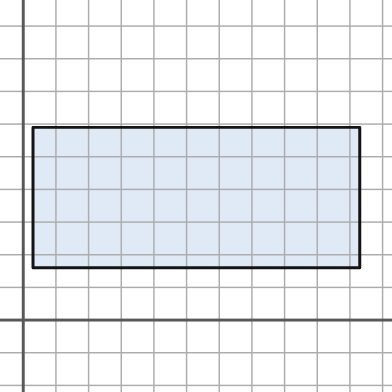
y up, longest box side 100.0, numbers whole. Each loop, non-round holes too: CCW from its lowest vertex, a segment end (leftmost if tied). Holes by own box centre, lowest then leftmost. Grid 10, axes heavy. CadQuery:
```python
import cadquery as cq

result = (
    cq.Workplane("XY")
    .moveTo(3.0, 16.0)
    .lineTo(103.0, 16.0)
    .lineTo(103.0, 59.0)
    .lineTo(3.0, 59.0)
    .close()
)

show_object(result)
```